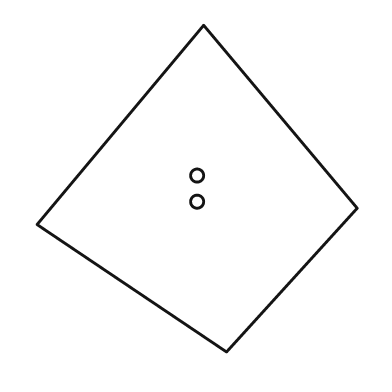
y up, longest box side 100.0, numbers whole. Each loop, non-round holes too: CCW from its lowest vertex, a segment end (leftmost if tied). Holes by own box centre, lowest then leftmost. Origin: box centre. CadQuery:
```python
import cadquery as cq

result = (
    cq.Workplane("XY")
    .moveTo(9.0, -50.0)
    .lineTo(49.0, -6.0)
    .lineTo(2.0, 50.0)
    .lineTo(-49.0, -11.0)
    .close()
    .moveTo(0.0, -4.0)
    .circle(2.0)
    .moveTo(0.0, 4.0)
    .circle(2.0)
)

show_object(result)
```